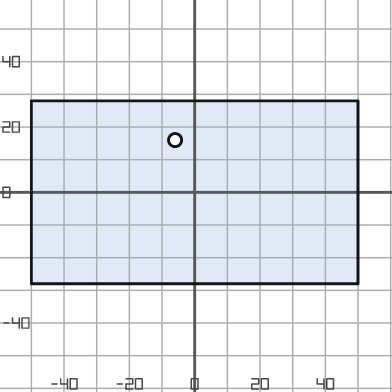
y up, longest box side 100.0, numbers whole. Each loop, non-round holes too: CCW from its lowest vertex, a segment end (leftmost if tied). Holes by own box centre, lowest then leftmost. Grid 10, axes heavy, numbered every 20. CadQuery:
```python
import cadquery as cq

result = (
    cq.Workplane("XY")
    .moveTo(-50.0, -28.0)
    .lineTo(50.0, -28.0)
    .lineTo(50.0, 28.0)
    .lineTo(-50.0, 28.0)
    .close()
    .moveTo(-6.0, 16.0)
    .circle(2.0)
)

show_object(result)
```